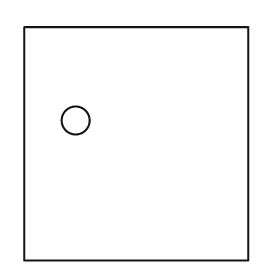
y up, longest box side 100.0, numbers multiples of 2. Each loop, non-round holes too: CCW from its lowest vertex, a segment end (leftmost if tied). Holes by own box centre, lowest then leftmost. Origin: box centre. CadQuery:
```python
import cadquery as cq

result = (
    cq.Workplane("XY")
    .moveTo(-48.0, -50.0)
    .lineTo(48.0, -50.0)
    .lineTo(48.0, 50.0)
    .lineTo(-48.0, 50.0)
    .close()
    .moveTo(-26.0, 10.0)
    .circle(6.0)
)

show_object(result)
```